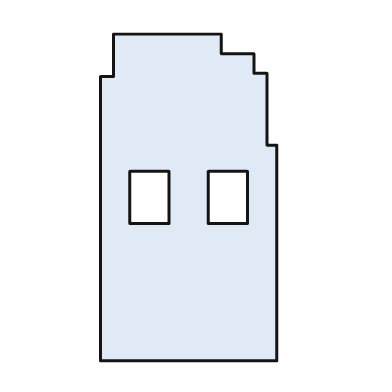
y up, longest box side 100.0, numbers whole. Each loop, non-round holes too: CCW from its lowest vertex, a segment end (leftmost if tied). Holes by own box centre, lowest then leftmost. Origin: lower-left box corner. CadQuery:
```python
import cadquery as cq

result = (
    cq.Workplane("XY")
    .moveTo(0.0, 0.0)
    .lineTo(54.0, 0.0)
    .lineTo(54.0, 66.0)
    .lineTo(51.0, 66.0)
    .lineTo(51.0, 88.0)
    .lineTo(47.0, 88.0)
    .lineTo(47.0, 94.0)
    .lineTo(37.0, 94.0)
    .lineTo(37.0, 100.0)
    .lineTo(4.0, 100.0)
    .lineTo(4.0, 87.0)
    .lineTo(0.0, 87.0)
    .close()
    .moveTo(9.0, 42.0)
    .lineTo(21.0, 42.0)
    .lineTo(21.0, 58.0)
    .lineTo(9.0, 58.0)
    .close()
    .moveTo(33.0, 42.0)
    .lineTo(45.0, 42.0)
    .lineTo(45.0, 58.0)
    .lineTo(33.0, 58.0)
    .close()
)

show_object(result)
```